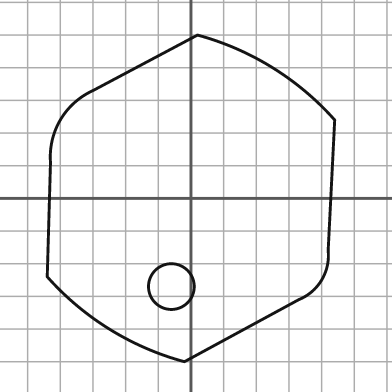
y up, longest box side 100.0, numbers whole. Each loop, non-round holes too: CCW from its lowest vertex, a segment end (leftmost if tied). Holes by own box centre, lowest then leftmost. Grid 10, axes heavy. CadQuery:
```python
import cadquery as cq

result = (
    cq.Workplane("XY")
    .moveTo(-2.0, -50.0)
    .lineTo(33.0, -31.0)
    .threePointArc((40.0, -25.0), (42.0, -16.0))
    .lineTo(44.0, 24.0)
    .threePointArc((25.0, 40.0), (2.0, 50.0))
    .lineTo(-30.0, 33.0)
    .threePointArc((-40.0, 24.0), (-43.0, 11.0))
    .lineTo(-44.0, -24.0)
    .threePointArc((-25.0, -40.0), (-2.0, -50.0))
    .close()
    .moveTo(-6.0, -27.0)
    .circle(7.0)
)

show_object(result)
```